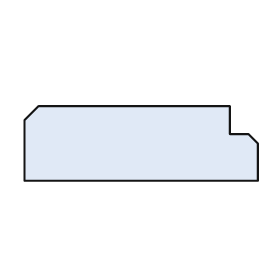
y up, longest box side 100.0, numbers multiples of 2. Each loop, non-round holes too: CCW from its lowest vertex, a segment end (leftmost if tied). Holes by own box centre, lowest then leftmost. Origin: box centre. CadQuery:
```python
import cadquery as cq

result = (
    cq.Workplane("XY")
    .moveTo(-50.0, -16.0)
    .lineTo(50.0, -16.0)
    .lineTo(50.0, 0.0)
    .lineTo(46.0, 4.0)
    .lineTo(38.0, 4.0)
    .lineTo(38.0, 16.0)
    .lineTo(-44.0, 16.0)
    .lineTo(-50.0, 10.0)
    .close()
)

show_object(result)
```